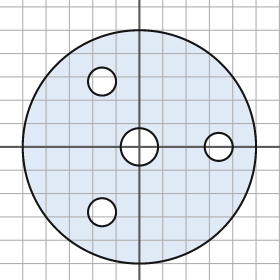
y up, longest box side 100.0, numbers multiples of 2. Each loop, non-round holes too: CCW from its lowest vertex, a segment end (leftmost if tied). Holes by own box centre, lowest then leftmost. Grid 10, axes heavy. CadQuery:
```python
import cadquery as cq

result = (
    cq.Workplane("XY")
    .moveTo(0.0, 0.0)
    .circle(50.0)
    .moveTo(-16.0, -28.0)
    .circle(6.0)
    .moveTo(0.0, 0.0)
    .circle(8.0)
    .moveTo(34.0, 0.0)
    .circle(6.0)
    .moveTo(-16.0, 28.0)
    .circle(6.0)
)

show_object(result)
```